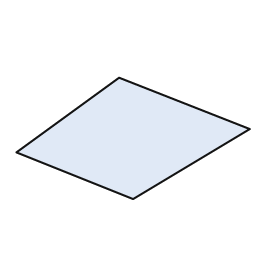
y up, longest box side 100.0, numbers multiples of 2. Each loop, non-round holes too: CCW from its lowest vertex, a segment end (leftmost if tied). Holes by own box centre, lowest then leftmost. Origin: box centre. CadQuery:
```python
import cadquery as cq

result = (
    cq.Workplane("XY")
    .moveTo(0.0, -26.0)
    .lineTo(50.0, 4.0)
    .lineTo(-6.0, 26.0)
    .lineTo(-50.0, -6.0)
    .close()
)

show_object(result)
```